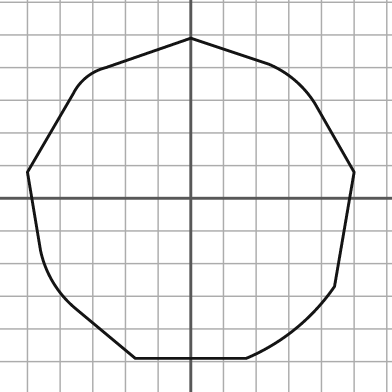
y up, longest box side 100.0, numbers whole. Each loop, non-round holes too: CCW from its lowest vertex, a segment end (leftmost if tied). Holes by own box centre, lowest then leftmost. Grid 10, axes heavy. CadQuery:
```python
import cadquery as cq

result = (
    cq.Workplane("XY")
    .moveTo(-17.0, -49.0)
    .lineTo(17.0, -49.0)
    .threePointArc((32.0, -40.0), (44.0, -27.0))
    .lineTo(50.0, 8.0)
    .lineTo(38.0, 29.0)
    .threePointArc((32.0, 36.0), (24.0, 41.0))
    .lineTo(0.0, 49.0)
    .lineTo(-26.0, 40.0)
    .threePointArc((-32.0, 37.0), (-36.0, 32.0))
    .lineTo(-50.0, 8.0)
    .lineTo(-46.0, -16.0)
    .threePointArc((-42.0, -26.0), (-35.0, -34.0))
    .close()
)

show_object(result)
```